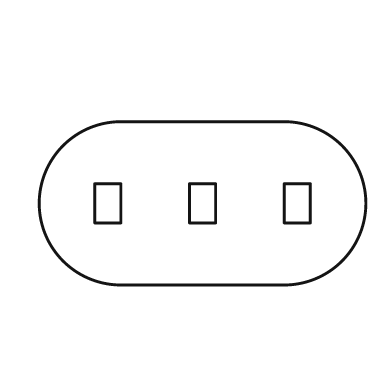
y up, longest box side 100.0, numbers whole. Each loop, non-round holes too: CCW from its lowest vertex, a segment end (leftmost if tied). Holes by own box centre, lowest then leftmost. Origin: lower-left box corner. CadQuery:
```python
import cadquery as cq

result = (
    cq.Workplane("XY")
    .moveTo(25.0, 0.0)
    .lineTo(75.0, 0.0)
    .threePointArc((100.0, 25.0), (75.0, 50.0))
    .lineTo(25.0, 50.0)
    .threePointArc((0.0, 25.0), (25.0, 0.0))
    .close()
    .moveTo(17.0, 19.0)
    .lineTo(25.0, 19.0)
    .lineTo(25.0, 31.0)
    .lineTo(17.0, 31.0)
    .close()
    .moveTo(46.0, 19.0)
    .lineTo(54.0, 19.0)
    .lineTo(54.0, 31.0)
    .lineTo(46.0, 31.0)
    .close()
    .moveTo(75.0, 19.0)
    .lineTo(83.0, 19.0)
    .lineTo(83.0, 31.0)
    .lineTo(75.0, 31.0)
    .close()
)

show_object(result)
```